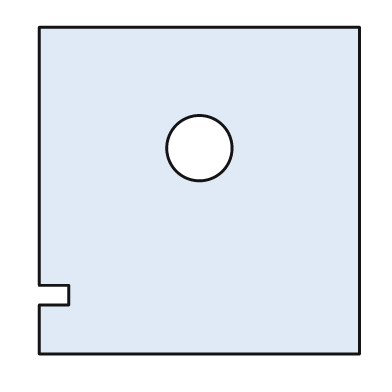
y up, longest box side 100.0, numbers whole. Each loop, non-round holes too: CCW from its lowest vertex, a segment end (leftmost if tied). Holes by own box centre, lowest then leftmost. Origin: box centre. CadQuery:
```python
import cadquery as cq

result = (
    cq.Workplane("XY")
    .moveTo(-49.0, -50.0)
    .lineTo(49.0, -50.0)
    .lineTo(49.0, 50.0)
    .lineTo(-49.0, 50.0)
    .lineTo(-49.0, -29.0)
    .lineTo(-40.0, -29.0)
    .lineTo(-40.0, -35.0)
    .lineTo(-49.0, -35.0)
    .close()
    .moveTo(0.0, 13.0)
    .circle(10.0)
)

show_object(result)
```